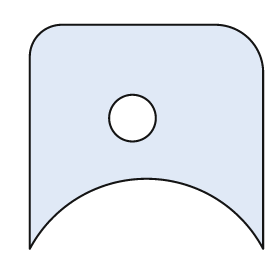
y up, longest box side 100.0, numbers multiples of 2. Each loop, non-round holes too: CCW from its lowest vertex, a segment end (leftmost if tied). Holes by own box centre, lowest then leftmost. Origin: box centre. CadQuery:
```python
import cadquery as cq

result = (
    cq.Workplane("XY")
    .moveTo(-50.0, -48.0)
    .threePointArc((0.0, -18.0), (50.0, -48.0))
    .lineTo(50.0, 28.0)
    .threePointArc((44.0, 42.0), (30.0, 48.0))
    .lineTo(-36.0, 48.0)
    .threePointArc((-46.0, 44.0), (-50.0, 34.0))
    .close()
    .moveTo(-6.0, 8.0)
    .circle(10.0)
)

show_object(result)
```